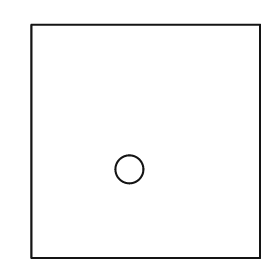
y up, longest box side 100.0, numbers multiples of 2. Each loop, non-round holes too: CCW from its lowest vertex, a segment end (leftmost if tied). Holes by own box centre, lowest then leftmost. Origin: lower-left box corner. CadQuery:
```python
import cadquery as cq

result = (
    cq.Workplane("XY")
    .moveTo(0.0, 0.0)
    .lineTo(98.0, 0.0)
    .lineTo(98.0, 100.0)
    .lineTo(0.0, 100.0)
    .close()
    .moveTo(42.0, 38.0)
    .circle(6.0)
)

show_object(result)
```